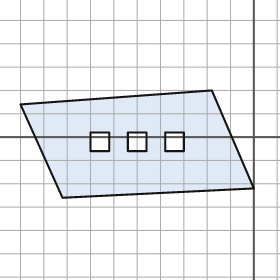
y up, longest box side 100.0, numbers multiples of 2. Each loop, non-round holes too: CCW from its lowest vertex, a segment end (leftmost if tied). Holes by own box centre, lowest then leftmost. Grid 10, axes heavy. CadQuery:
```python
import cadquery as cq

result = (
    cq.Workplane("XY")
    .moveTo(-82.0, -26.0)
    .lineTo(0.0, -22.0)
    .lineTo(-18.0, 20.0)
    .lineTo(-100.0, 14.0)
    .close()
    .moveTo(-70.0, -6.0)
    .lineTo(-62.0, -6.0)
    .lineTo(-62.0, 2.0)
    .lineTo(-70.0, 2.0)
    .close()
    .moveTo(-54.0, -6.0)
    .lineTo(-46.0, -6.0)
    .lineTo(-46.0, 2.0)
    .lineTo(-54.0, 2.0)
    .close()
    .moveTo(-38.0, -6.0)
    .lineTo(-30.0, -6.0)
    .lineTo(-30.0, 2.0)
    .lineTo(-38.0, 2.0)
    .close()
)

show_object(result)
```